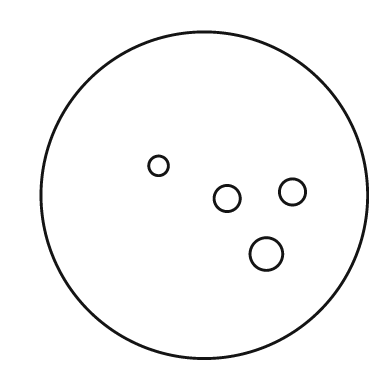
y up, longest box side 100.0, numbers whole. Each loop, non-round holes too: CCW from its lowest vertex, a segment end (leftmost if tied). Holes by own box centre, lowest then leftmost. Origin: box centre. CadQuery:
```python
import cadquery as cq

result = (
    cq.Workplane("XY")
    .moveTo(0.0, 0.0)
    .circle(50.0)
    .moveTo(19.0, -18.0)
    .circle(5.0)
    .moveTo(7.0, -1.0)
    .circle(4.0)
    .moveTo(27.0, 1.0)
    .circle(4.0)
    .moveTo(-14.0, 9.0)
    .circle(3.0)
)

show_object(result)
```